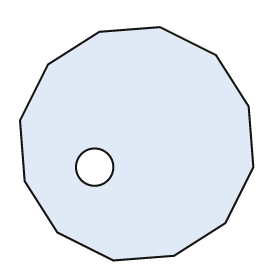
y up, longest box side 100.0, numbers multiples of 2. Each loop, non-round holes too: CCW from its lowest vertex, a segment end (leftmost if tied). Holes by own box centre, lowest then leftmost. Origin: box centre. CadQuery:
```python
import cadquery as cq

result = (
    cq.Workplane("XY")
    .moveTo(-10.0, -50.0)
    .lineTo(16.0, -48.0)
    .lineTo(38.0, -34.0)
    .lineTo(50.0, -10.0)
    .lineTo(48.0, 16.0)
    .lineTo(34.0, 38.0)
    .lineTo(10.0, 50.0)
    .lineTo(-16.0, 48.0)
    .lineTo(-38.0, 34.0)
    .lineTo(-50.0, 10.0)
    .lineTo(-48.0, -16.0)
    .lineTo(-34.0, -38.0)
    .close()
    .moveTo(-18.0, -10.0)
    .circle(8.0)
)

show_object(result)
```